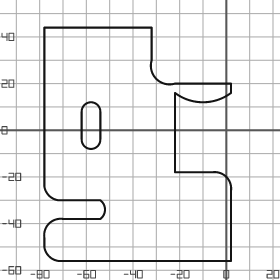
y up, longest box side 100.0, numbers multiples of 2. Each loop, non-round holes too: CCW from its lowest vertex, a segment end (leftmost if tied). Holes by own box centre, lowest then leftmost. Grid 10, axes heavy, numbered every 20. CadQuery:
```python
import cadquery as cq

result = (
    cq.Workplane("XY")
    .moveTo(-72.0, -56.0)
    .lineTo(2.0, -56.0)
    .lineTo(2.0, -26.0)
    .threePointArc((0.0, -20.0), (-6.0, -18.0))
    .lineTo(-22.0, -18.0)
    .lineTo(-22.0, 16.0)
    .threePointArc((-10.0, 12.0), (2.0, 16.0))
    .lineTo(2.0, 20.0)
    .lineTo(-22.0, 20.0)
    .threePointArc((-30.0, 22.0), (-32.0, 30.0))
    .lineTo(-32.0, 44.0)
    .lineTo(-78.0, 44.0)
    .lineTo(-78.0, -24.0)
    .threePointArc((-76.0, -28.0), (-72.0, -30.0))
    .lineTo(-54.0, -30.0)
    .threePointArc((-52.0, -34.0), (-54.0, -38.0))
    .lineTo(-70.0, -38.0)
    .threePointArc((-76.0, -40.0), (-78.0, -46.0))
    .lineTo(-78.0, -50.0)
    .threePointArc((-76.0, -54.0), (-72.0, -56.0))
    .close()
    .moveTo(-62.0, -4.0)
    .threePointArc((-58.0, -8.0), (-54.0, -4.0))
    .lineTo(-54.0, 8.0)
    .threePointArc((-58.0, 12.0), (-62.0, 8.0))
    .close()
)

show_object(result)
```